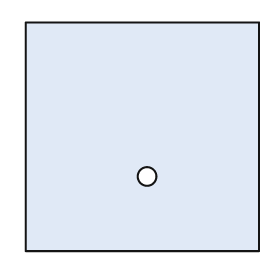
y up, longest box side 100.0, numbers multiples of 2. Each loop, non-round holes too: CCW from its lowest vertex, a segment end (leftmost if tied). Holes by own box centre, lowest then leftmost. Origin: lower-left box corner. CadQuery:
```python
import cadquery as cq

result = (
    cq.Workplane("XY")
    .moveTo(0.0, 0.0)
    .lineTo(100.0, 0.0)
    .lineTo(100.0, 98.0)
    .lineTo(0.0, 98.0)
    .close()
    .moveTo(52.0, 32.0)
    .circle(4.0)
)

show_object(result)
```